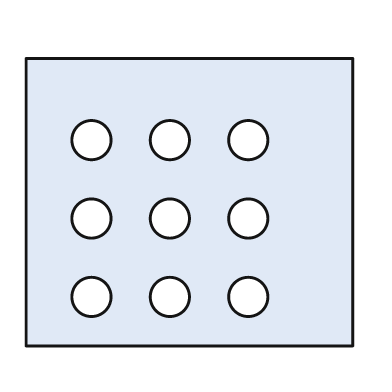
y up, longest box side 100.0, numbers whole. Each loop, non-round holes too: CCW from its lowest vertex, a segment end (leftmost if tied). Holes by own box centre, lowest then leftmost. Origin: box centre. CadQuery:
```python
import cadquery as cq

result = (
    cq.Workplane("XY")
    .moveTo(-50.0, -44.0)
    .lineTo(50.0, -44.0)
    .lineTo(50.0, 44.0)
    .lineTo(-50.0, 44.0)
    .close()
    .moveTo(-30.0, -29.0)
    .circle(6.0)
    .moveTo(-6.0, -29.0)
    .circle(6.0)
    .moveTo(18.0, -29.0)
    .circle(6.0)
    .moveTo(-30.0, -5.0)
    .circle(6.0)
    .moveTo(-6.0, -5.0)
    .circle(6.0)
    .moveTo(18.0, -5.0)
    .circle(6.0)
    .moveTo(-30.0, 19.0)
    .circle(6.0)
    .moveTo(-6.0, 19.0)
    .circle(6.0)
    .moveTo(18.0, 19.0)
    .circle(6.0)
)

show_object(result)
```